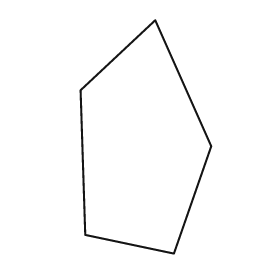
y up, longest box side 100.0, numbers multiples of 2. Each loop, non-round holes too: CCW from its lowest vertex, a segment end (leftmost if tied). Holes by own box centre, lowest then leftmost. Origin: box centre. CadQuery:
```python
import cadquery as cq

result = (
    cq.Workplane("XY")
    .moveTo(12.0, -50.0)
    .lineTo(28.0, -4.0)
    .lineTo(4.0, 50.0)
    .lineTo(-28.0, 20.0)
    .lineTo(-26.0, -42.0)
    .close()
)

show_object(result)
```